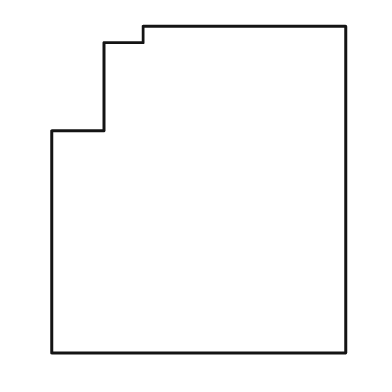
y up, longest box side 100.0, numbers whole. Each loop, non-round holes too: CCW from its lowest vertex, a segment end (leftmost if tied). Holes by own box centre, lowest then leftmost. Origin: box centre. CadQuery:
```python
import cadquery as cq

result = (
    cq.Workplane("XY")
    .moveTo(-45.0, -50.0)
    .lineTo(45.0, -50.0)
    .lineTo(45.0, 50.0)
    .lineTo(-17.0, 50.0)
    .lineTo(-17.0, 45.0)
    .lineTo(-29.0, 45.0)
    .lineTo(-29.0, 18.0)
    .lineTo(-45.0, 18.0)
    .close()
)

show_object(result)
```